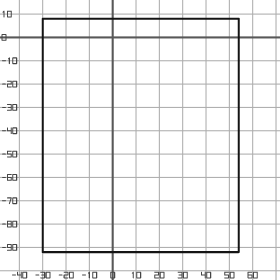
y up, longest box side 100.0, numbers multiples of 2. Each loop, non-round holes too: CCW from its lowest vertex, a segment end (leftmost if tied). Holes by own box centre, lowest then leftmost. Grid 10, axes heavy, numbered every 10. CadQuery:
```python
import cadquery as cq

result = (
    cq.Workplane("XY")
    .moveTo(-30.0, -92.0)
    .lineTo(54.0, -92.0)
    .lineTo(54.0, 8.0)
    .lineTo(-30.0, 8.0)
    .close()
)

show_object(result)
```